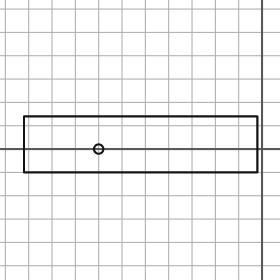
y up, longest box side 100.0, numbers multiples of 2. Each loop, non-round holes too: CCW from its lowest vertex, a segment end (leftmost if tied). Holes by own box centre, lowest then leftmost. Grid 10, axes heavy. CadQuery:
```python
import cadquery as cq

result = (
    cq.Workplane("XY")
    .moveTo(-102.0, -10.0)
    .lineTo(-2.0, -10.0)
    .lineTo(-2.0, 14.0)
    .lineTo(-102.0, 14.0)
    .close()
    .moveTo(-70.0, 0.0)
    .circle(2.0)
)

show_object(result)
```